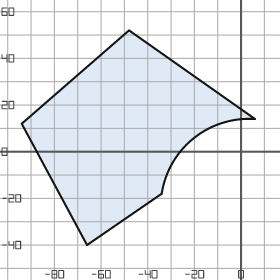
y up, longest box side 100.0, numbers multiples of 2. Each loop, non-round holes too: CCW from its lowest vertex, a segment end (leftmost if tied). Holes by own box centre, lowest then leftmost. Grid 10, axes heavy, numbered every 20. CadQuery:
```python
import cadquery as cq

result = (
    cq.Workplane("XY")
    .moveTo(-66.0, -40.0)
    .lineTo(-34.0, -18.0)
    .threePointArc((-20.0, 6.0), (6.0, 14.0))
    .lineTo(-48.0, 52.0)
    .lineTo(-94.0, 12.0)
    .close()
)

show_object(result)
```